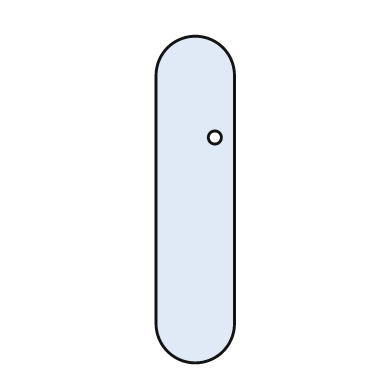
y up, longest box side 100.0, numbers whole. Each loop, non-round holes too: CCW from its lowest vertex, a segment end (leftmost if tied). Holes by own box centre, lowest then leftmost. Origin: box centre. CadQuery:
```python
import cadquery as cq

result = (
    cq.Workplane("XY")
    .moveTo(-12.0, -38.0)
    .threePointArc((0.0, -50.0), (12.0, -38.0))
    .lineTo(12.0, 38.0)
    .threePointArc((0.0, 50.0), (-12.0, 38.0))
    .close()
    .moveTo(6.0, 19.0)
    .circle(2.0)
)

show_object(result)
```